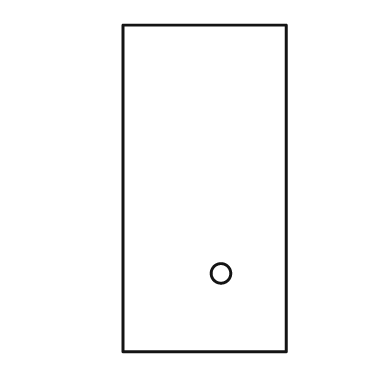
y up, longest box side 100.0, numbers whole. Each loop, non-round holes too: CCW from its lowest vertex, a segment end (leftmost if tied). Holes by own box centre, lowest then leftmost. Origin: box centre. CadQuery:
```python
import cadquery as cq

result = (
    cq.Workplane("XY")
    .moveTo(-25.0, -50.0)
    .lineTo(25.0, -50.0)
    .lineTo(25.0, 50.0)
    .lineTo(-25.0, 50.0)
    .close()
    .moveTo(5.0, -26.0)
    .circle(3.0)
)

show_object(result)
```